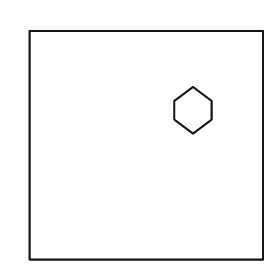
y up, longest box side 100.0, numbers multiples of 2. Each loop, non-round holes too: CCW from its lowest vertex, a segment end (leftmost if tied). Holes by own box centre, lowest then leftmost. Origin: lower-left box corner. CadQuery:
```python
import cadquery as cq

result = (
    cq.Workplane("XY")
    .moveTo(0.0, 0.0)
    .lineTo(100.0, 0.0)
    .lineTo(100.0, 98.0)
    .lineTo(0.0, 98.0)
    .close()
    .moveTo(70.0, 54.0)
    .lineTo(78.0, 60.0)
    .lineTo(78.0, 68.0)
    .lineTo(70.0, 74.0)
    .lineTo(62.0, 68.0)
    .lineTo(62.0, 60.0)
    .close()
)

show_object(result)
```